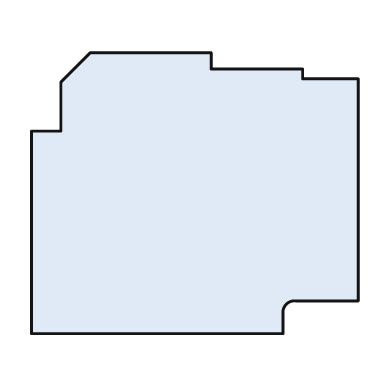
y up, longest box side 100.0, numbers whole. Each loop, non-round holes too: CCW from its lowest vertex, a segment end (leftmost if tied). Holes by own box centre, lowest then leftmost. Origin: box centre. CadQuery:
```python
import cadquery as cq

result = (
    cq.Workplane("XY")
    .moveTo(-50.0, -43.0)
    .lineTo(27.0, -43.0)
    .lineTo(27.0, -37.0)
    .threePointArc((28.0, -34.0), (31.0, -33.0))
    .lineTo(50.0, -33.0)
    .lineTo(50.0, 35.0)
    .lineTo(33.0, 35.0)
    .lineTo(33.0, 38.0)
    .lineTo(5.0, 38.0)
    .lineTo(5.0, 43.0)
    .lineTo(-32.0, 43.0)
    .lineTo(-41.0, 34.0)
    .lineTo(-41.0, 19.0)
    .lineTo(-50.0, 19.0)
    .close()
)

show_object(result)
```